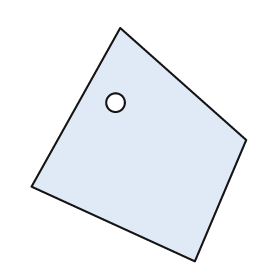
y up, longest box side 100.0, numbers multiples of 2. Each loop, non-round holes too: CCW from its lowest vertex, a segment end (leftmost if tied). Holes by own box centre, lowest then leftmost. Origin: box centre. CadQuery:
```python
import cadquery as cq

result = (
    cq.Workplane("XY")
    .moveTo(24.0, -50.0)
    .lineTo(46.0, 2.0)
    .lineTo(-8.0, 50.0)
    .lineTo(-46.0, -18.0)
    .close()
    .moveTo(-10.0, 18.0)
    .circle(4.0)
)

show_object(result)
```